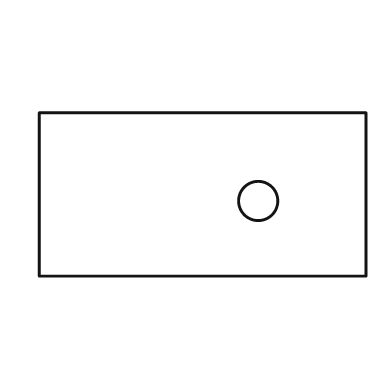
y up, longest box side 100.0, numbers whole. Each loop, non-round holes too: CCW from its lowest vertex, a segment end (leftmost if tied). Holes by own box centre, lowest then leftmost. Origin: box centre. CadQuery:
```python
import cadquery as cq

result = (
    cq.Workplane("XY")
    .moveTo(-50.0, -25.0)
    .lineTo(50.0, -25.0)
    .lineTo(50.0, 25.0)
    .lineTo(-50.0, 25.0)
    .close()
    .moveTo(17.0, -2.0)
    .circle(6.0)
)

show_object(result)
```